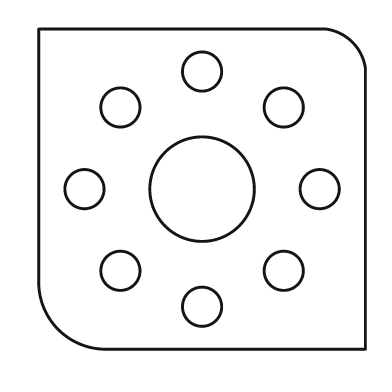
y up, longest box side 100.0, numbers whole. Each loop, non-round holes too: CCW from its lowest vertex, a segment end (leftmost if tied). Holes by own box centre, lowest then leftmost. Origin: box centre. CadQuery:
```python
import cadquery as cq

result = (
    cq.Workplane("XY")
    .moveTo(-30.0, -49.0)
    .lineTo(50.0, -49.0)
    .lineTo(50.0, 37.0)
    .threePointArc((46.0, 45.0), (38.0, 49.0))
    .lineTo(-50.0, 49.0)
    .lineTo(-50.0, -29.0)
    .threePointArc((-44.0, -43.0), (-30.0, -49.0))
    .close()
    .moveTo(0.0, -36.0)
    .circle(6.0)
    .moveTo(-25.0, -25.0)
    .circle(6.0)
    .moveTo(25.0, -25.0)
    .circle(6.0)
    .moveTo(-36.0, 0.0)
    .circle(6.0)
    .moveTo(0.0, 0.0)
    .circle(16.0)
    .moveTo(36.0, 0.0)
    .circle(6.0)
    .moveTo(-25.0, 25.0)
    .circle(6.0)
    .moveTo(25.0, 25.0)
    .circle(6.0)
    .moveTo(0.0, 36.0)
    .circle(6.0)
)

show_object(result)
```